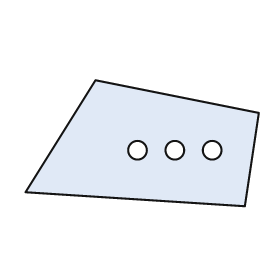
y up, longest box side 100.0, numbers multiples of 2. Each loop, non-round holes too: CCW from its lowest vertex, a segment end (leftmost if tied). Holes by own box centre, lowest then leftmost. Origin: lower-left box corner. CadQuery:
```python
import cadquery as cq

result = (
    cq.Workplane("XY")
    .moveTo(94.0, 0.0)
    .lineTo(100.0, 40.0)
    .lineTo(30.0, 54.0)
    .lineTo(0.0, 6.0)
    .close()
    .moveTo(48.0, 24.0)
    .circle(4.0)
    .moveTo(64.0, 24.0)
    .circle(4.0)
    .moveTo(80.0, 24.0)
    .circle(4.0)
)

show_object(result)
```